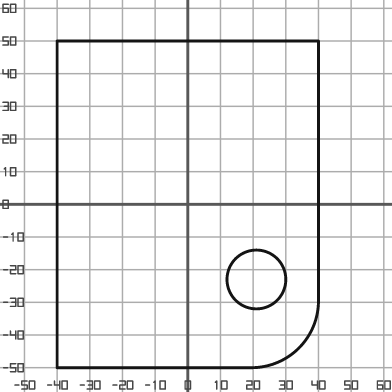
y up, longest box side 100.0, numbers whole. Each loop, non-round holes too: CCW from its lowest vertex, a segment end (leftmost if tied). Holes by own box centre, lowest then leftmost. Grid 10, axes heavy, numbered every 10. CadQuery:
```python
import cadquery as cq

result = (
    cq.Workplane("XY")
    .moveTo(-40.0, -50.0)
    .lineTo(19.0, -50.0)
    .threePointArc((34.0, -44.0), (40.0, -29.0))
    .lineTo(40.0, 50.0)
    .lineTo(-40.0, 50.0)
    .close()
    .moveTo(21.0, -23.0)
    .circle(9.0)
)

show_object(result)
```